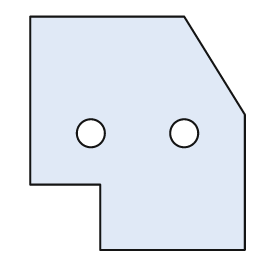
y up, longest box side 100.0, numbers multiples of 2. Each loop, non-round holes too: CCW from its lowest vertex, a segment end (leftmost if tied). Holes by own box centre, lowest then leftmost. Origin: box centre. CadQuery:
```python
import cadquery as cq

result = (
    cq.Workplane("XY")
    .moveTo(-16.0, -50.0)
    .lineTo(46.0, -50.0)
    .lineTo(46.0, 8.0)
    .lineTo(20.0, 50.0)
    .lineTo(-46.0, 50.0)
    .lineTo(-46.0, -22.0)
    .lineTo(-16.0, -22.0)
    .close()
    .moveTo(-20.0, 0.0)
    .circle(6.0)
    .moveTo(20.0, 0.0)
    .circle(6.0)
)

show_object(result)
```